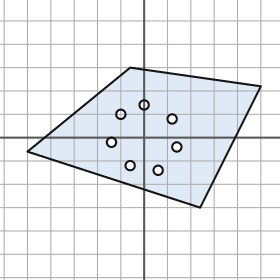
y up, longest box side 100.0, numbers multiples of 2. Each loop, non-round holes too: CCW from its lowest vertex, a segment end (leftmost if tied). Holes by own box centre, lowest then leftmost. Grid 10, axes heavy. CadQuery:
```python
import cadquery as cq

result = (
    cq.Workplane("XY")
    .moveTo(24.0, -30.0)
    .lineTo(50.0, 22.0)
    .lineTo(-6.0, 30.0)
    .lineTo(-50.0, -6.0)
    .close()
    .moveTo(6.0, -14.0)
    .circle(2.0)
    .moveTo(-6.0, -12.0)
    .circle(2.0)
    .moveTo(14.0, -4.0)
    .circle(2.0)
    .moveTo(-14.0, -2.0)
    .circle(2.0)
    .moveTo(12.0, 8.0)
    .circle(2.0)
    .moveTo(-10.0, 10.0)
    .circle(2.0)
    .moveTo(0.0, 14.0)
    .circle(2.0)
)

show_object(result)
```